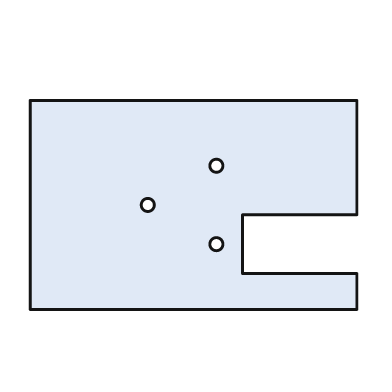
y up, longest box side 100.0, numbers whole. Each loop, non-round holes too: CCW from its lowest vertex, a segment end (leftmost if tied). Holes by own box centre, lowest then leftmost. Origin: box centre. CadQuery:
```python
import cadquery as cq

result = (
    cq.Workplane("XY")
    .moveTo(-50.0, -32.0)
    .lineTo(50.0, -32.0)
    .lineTo(50.0, -21.0)
    .lineTo(15.0, -21.0)
    .lineTo(15.0, -3.0)
    .lineTo(50.0, -3.0)
    .lineTo(50.0, 32.0)
    .lineTo(-50.0, 32.0)
    .close()
    .moveTo(7.0, -12.0)
    .circle(2.0)
    .moveTo(-14.0, 0.0)
    .circle(2.0)
    .moveTo(7.0, 12.0)
    .circle(2.0)
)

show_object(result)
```